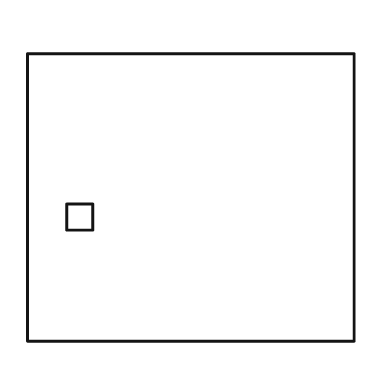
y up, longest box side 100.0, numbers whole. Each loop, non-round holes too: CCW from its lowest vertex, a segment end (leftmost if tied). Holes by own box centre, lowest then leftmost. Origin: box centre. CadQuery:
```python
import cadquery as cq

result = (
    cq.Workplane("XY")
    .moveTo(-50.0, -44.0)
    .lineTo(50.0, -44.0)
    .lineTo(50.0, 44.0)
    .lineTo(-50.0, 44.0)
    .close()
    .moveTo(-38.0, -10.0)
    .lineTo(-30.0, -10.0)
    .lineTo(-30.0, -2.0)
    .lineTo(-38.0, -2.0)
    .close()
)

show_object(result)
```